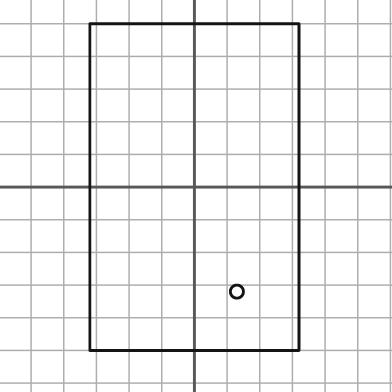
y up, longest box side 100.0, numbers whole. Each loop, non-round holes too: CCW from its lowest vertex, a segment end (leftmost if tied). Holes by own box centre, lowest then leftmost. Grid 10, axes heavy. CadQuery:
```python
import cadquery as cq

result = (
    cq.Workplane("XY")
    .moveTo(-32.0, -50.0)
    .lineTo(32.0, -50.0)
    .lineTo(32.0, 50.0)
    .lineTo(-32.0, 50.0)
    .close()
    .moveTo(13.0, -32.0)
    .circle(2.0)
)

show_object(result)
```